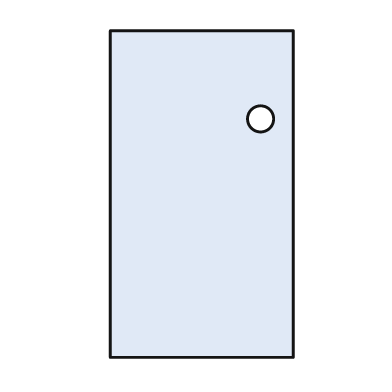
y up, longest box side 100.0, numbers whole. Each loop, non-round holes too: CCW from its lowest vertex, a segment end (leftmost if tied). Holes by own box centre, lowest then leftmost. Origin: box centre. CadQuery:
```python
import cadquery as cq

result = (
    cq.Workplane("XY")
    .moveTo(-28.0, -50.0)
    .lineTo(28.0, -50.0)
    .lineTo(28.0, 50.0)
    .lineTo(-28.0, 50.0)
    .close()
    .moveTo(18.0, 23.0)
    .circle(4.0)
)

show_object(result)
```